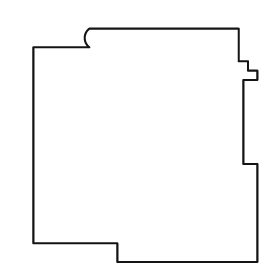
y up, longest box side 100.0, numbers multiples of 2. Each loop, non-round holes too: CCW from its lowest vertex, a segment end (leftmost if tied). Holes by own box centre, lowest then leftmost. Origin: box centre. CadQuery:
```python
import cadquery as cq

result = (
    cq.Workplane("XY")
    .moveTo(-12.0, -50.0)
    .lineTo(48.0, -50.0)
    .lineTo(48.0, -8.0)
    .lineTo(42.0, -8.0)
    .lineTo(42.0, 28.0)
    .lineTo(48.0, 28.0)
    .lineTo(48.0, 32.0)
    .lineTo(44.0, 32.0)
    .lineTo(44.0, 36.0)
    .lineTo(40.0, 36.0)
    .lineTo(40.0, 50.0)
    .lineTo(-24.0, 50.0)
    .threePointArc((-26.0, 46.0), (-24.0, 42.0))
    .lineTo(-48.0, 42.0)
    .lineTo(-48.0, -42.0)
    .lineTo(-12.0, -42.0)
    .close()
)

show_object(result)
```